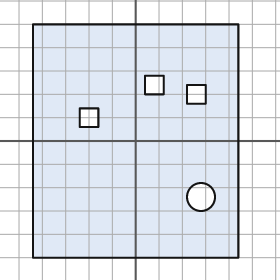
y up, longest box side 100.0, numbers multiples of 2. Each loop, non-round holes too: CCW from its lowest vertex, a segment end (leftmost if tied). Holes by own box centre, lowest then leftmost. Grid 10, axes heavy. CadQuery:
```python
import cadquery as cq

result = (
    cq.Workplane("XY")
    .moveTo(-44.0, -50.0)
    .lineTo(44.0, -50.0)
    .lineTo(44.0, 50.0)
    .lineTo(-44.0, 50.0)
    .close()
    .moveTo(28.0, -24.0)
    .circle(6.0)
    .moveTo(-24.0, 6.0)
    .lineTo(-16.0, 6.0)
    .lineTo(-16.0, 14.0)
    .lineTo(-24.0, 14.0)
    .close()
    .moveTo(22.0, 16.0)
    .lineTo(30.0, 16.0)
    .lineTo(30.0, 24.0)
    .lineTo(22.0, 24.0)
    .close()
    .moveTo(4.0, 20.0)
    .lineTo(12.0, 20.0)
    .lineTo(12.0, 28.0)
    .lineTo(4.0, 28.0)
    .close()
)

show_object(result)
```